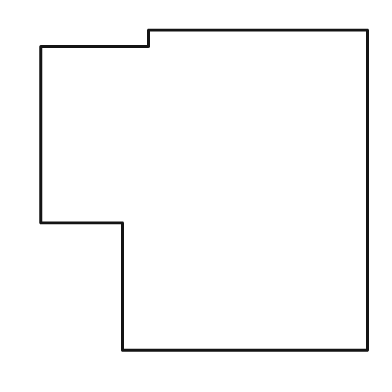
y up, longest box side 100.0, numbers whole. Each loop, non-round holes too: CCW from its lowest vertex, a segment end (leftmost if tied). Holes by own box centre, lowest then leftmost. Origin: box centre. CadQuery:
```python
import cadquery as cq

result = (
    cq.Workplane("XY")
    .moveTo(-25.0, -49.0)
    .lineTo(50.0, -49.0)
    .lineTo(50.0, 49.0)
    .lineTo(-17.0, 49.0)
    .lineTo(-17.0, 44.0)
    .lineTo(-50.0, 44.0)
    .lineTo(-50.0, -10.0)
    .lineTo(-25.0, -10.0)
    .close()
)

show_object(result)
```